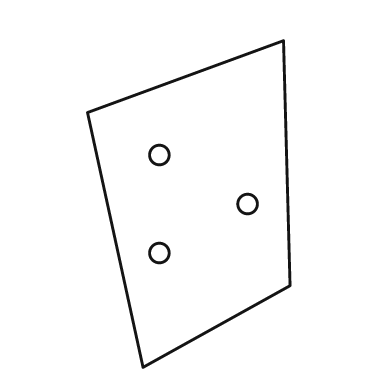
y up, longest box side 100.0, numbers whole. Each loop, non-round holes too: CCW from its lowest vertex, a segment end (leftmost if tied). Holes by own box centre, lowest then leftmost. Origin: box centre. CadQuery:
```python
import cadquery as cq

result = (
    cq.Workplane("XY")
    .moveTo(-14.0, -50.0)
    .lineTo(31.0, -25.0)
    .lineTo(29.0, 50.0)
    .lineTo(-31.0, 28.0)
    .close()
    .moveTo(-9.0, -15.0)
    .circle(3.0)
    .moveTo(18.0, 0.0)
    .circle(3.0)
    .moveTo(-9.0, 15.0)
    .circle(3.0)
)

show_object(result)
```